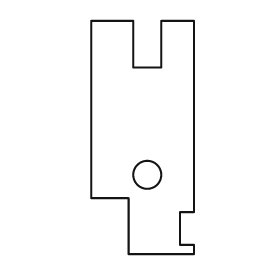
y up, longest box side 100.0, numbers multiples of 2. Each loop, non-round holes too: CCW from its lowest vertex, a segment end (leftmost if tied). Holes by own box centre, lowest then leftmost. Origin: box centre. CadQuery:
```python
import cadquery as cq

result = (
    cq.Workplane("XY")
    .moveTo(-6.0, -50.0)
    .lineTo(22.0, -50.0)
    .lineTo(22.0, -46.0)
    .lineTo(16.0, -46.0)
    .lineTo(16.0, -32.0)
    .lineTo(22.0, -32.0)
    .lineTo(22.0, 50.0)
    .lineTo(8.0, 50.0)
    .lineTo(8.0, 30.0)
    .lineTo(-4.0, 30.0)
    .lineTo(-4.0, 50.0)
    .lineTo(-22.0, 50.0)
    .lineTo(-22.0, -26.0)
    .lineTo(-6.0, -26.0)
    .close()
    .moveTo(2.0, -16.0)
    .circle(6.0)
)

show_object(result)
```